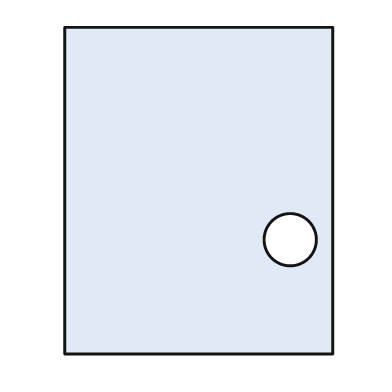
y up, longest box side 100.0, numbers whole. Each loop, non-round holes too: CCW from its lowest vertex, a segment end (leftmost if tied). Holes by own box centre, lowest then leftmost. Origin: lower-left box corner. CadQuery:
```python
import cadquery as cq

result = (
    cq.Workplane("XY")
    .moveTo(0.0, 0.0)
    .lineTo(82.0, 0.0)
    .lineTo(82.0, 100.0)
    .lineTo(0.0, 100.0)
    .close()
    .moveTo(69.0, 35.0)
    .circle(8.0)
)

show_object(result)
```